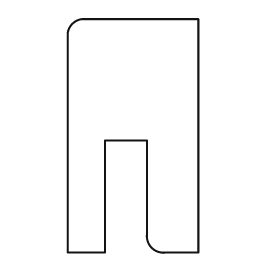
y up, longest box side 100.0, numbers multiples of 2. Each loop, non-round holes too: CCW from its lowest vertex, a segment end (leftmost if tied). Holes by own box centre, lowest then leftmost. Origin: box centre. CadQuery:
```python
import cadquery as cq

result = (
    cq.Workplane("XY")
    .moveTo(-28.0, -50.0)
    .lineTo(-12.0, -50.0)
    .lineTo(-12.0, -2.0)
    .lineTo(6.0, -2.0)
    .lineTo(6.0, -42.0)
    .threePointArc((8.0, -48.0), (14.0, -50.0))
    .lineTo(28.0, -50.0)
    .lineTo(28.0, 50.0)
    .lineTo(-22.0, 50.0)
    .threePointArc((-26.0, 48.0), (-28.0, 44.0))
    .close()
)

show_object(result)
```